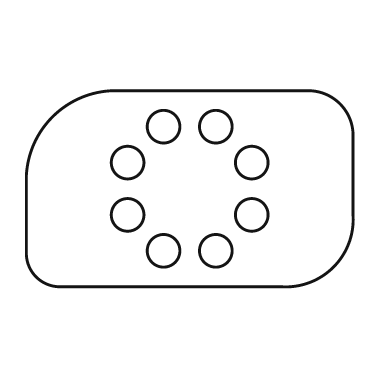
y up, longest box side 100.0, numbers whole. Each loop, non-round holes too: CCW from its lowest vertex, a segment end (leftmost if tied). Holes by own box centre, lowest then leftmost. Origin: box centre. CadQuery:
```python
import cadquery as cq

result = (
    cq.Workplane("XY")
    .moveTo(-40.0, -30.0)
    .lineTo(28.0, -30.0)
    .threePointArc((44.0, -24.0), (50.0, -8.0))
    .lineTo(50.0, 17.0)
    .threePointArc((46.0, 26.0), (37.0, 30.0))
    .lineTo(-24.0, 30.0)
    .threePointArc((-42.0, 22.0), (-50.0, 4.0))
    .lineTo(-50.0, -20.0)
    .threePointArc((-47.0, -27.0), (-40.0, -30.0))
    .close()
    .moveTo(-8.0, -19.0)
    .circle(5.0)
    .moveTo(8.0, -19.0)
    .circle(5.0)
    .moveTo(-19.0, -8.0)
    .circle(5.0)
    .moveTo(19.0, -8.0)
    .circle(5.0)
    .moveTo(-19.0, 8.0)
    .circle(5.0)
    .moveTo(19.0, 8.0)
    .circle(5.0)
    .moveTo(-8.0, 19.0)
    .circle(5.0)
    .moveTo(8.0, 19.0)
    .circle(5.0)
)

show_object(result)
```